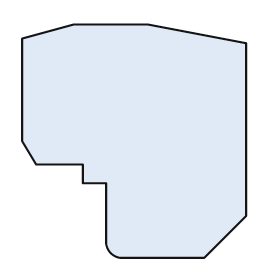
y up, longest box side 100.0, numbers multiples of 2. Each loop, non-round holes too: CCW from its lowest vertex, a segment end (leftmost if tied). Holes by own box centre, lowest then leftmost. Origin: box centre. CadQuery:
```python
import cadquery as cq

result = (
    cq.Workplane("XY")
    .moveTo(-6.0, -50.0)
    .lineTo(30.0, -50.0)
    .lineTo(48.0, -32.0)
    .lineTo(48.0, 42.0)
    .lineTo(6.0, 50.0)
    .lineTo(-26.0, 50.0)
    .lineTo(-48.0, 44.0)
    .lineTo(-48.0, 0.0)
    .lineTo(-42.0, -10.0)
    .lineTo(-22.0, -10.0)
    .lineTo(-22.0, -18.0)
    .lineTo(-12.0, -18.0)
    .lineTo(-12.0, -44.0)
    .threePointArc((-10.0, -48.0), (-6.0, -50.0))
    .close()
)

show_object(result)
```